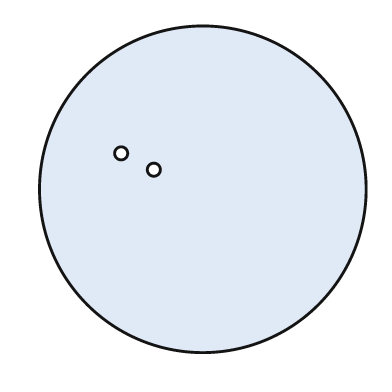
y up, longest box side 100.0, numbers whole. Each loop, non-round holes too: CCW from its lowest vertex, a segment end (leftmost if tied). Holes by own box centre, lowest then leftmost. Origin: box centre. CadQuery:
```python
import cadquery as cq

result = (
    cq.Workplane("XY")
    .moveTo(0.0, 0.0)
    .circle(50.0)
    .moveTo(-15.0, 6.0)
    .circle(2.0)
    .moveTo(-25.0, 11.0)
    .circle(2.0)
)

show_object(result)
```